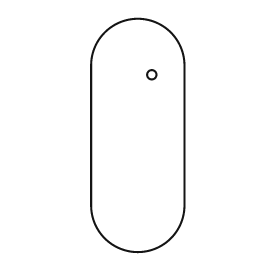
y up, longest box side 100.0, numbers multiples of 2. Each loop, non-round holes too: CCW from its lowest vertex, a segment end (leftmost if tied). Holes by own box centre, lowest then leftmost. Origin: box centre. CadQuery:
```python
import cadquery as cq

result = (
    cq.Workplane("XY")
    .moveTo(-20.0, -30.0)
    .threePointArc((0.0, -50.0), (20.0, -30.0))
    .lineTo(20.0, 30.0)
    .threePointArc((0.0, 50.0), (-20.0, 30.0))
    .close()
    .moveTo(6.0, 26.0)
    .circle(2.0)
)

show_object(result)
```